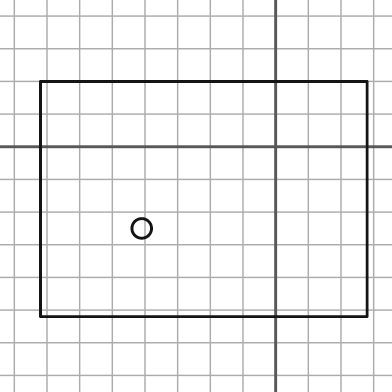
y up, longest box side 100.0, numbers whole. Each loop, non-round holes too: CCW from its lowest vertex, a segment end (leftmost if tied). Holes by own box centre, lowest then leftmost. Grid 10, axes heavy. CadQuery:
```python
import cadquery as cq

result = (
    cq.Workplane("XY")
    .moveTo(-72.0, -52.0)
    .lineTo(28.0, -52.0)
    .lineTo(28.0, 20.0)
    .lineTo(-72.0, 20.0)
    .close()
    .moveTo(-41.0, -25.0)
    .circle(3.0)
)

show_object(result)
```